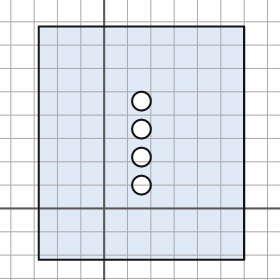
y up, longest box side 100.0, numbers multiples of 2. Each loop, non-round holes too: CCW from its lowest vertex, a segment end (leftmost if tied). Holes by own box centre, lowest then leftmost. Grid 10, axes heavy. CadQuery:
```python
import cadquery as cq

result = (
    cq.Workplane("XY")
    .moveTo(-28.0, -22.0)
    .lineTo(60.0, -22.0)
    .lineTo(60.0, 78.0)
    .lineTo(-28.0, 78.0)
    .close()
    .moveTo(16.0, 10.0)
    .circle(4.0)
    .moveTo(16.0, 22.0)
    .circle(4.0)
    .moveTo(16.0, 34.0)
    .circle(4.0)
    .moveTo(16.0, 46.0)
    .circle(4.0)
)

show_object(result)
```